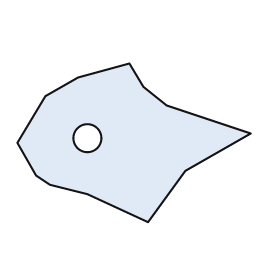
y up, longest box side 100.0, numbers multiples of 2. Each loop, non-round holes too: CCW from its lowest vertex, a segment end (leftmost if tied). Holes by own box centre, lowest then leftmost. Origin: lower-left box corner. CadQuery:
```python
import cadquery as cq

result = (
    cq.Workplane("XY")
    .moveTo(56.0, 0.0)
    .lineTo(72.0, 22.0)
    .lineTo(100.0, 38.0)
    .lineTo(64.0, 50.0)
    .lineTo(54.0, 58.0)
    .lineTo(48.0, 68.0)
    .lineTo(26.0, 62.0)
    .lineTo(12.0, 54.0)
    .lineTo(0.0, 34.0)
    .lineTo(8.0, 20.0)
    .lineTo(14.0, 16.0)
    .lineTo(30.0, 12.0)
    .close()
    .moveTo(30.0, 36.0)
    .circle(6.0)
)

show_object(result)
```